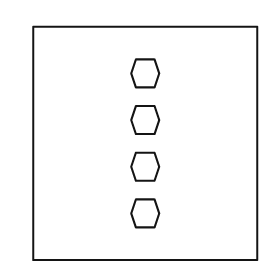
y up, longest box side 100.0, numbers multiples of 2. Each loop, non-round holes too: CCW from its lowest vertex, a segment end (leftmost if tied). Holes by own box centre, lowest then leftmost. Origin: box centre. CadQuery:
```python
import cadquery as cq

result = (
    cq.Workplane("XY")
    .moveTo(-48.0, -50.0)
    .lineTo(48.0, -50.0)
    .lineTo(48.0, 50.0)
    .lineTo(-48.0, 50.0)
    .close()
    .moveTo(-4.0, -36.0)
    .lineTo(4.0, -36.0)
    .lineTo(6.0, -30.0)
    .lineTo(4.0, -24.0)
    .lineTo(-4.0, -24.0)
    .lineTo(-6.0, -30.0)
    .close()
    .moveTo(-4.0, -16.0)
    .lineTo(4.0, -16.0)
    .lineTo(6.0, -10.0)
    .lineTo(4.0, -4.0)
    .lineTo(-4.0, -4.0)
    .lineTo(-6.0, -10.0)
    .close()
    .moveTo(-4.0, 4.0)
    .lineTo(4.0, 4.0)
    .lineTo(6.0, 10.0)
    .lineTo(4.0, 16.0)
    .lineTo(-4.0, 16.0)
    .lineTo(-6.0, 10.0)
    .close()
    .moveTo(-4.0, 24.0)
    .lineTo(4.0, 24.0)
    .lineTo(6.0, 30.0)
    .lineTo(4.0, 36.0)
    .lineTo(-4.0, 36.0)
    .lineTo(-6.0, 30.0)
    .close()
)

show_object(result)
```